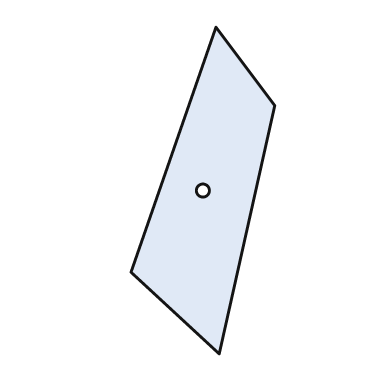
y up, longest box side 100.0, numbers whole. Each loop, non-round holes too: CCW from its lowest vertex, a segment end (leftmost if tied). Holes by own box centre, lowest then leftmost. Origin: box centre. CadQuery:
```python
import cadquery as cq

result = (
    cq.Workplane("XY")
    .moveTo(5.0, -50.0)
    .lineTo(22.0, 26.0)
    .lineTo(4.0, 50.0)
    .lineTo(-22.0, -25.0)
    .close()
    .moveTo(0.0, 0.0)
    .circle(2.0)
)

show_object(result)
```